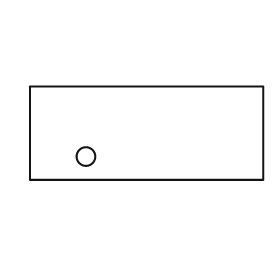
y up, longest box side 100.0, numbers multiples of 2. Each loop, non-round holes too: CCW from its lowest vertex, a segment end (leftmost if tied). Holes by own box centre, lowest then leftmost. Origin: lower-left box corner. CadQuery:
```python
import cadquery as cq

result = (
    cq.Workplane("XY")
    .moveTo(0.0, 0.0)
    .lineTo(100.0, 0.0)
    .lineTo(100.0, 40.0)
    .lineTo(0.0, 40.0)
    .close()
    .moveTo(24.0, 10.0)
    .circle(4.0)
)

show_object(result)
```